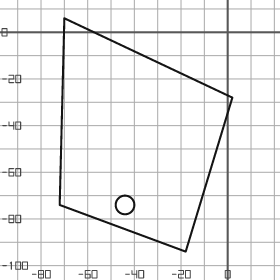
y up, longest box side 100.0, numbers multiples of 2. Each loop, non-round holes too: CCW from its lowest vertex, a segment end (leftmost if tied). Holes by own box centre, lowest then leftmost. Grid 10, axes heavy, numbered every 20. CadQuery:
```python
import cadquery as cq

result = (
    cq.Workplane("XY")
    .moveTo(-18.0, -94.0)
    .lineTo(2.0, -28.0)
    .lineTo(-70.0, 6.0)
    .lineTo(-72.0, -74.0)
    .close()
    .moveTo(-44.0, -74.0)
    .circle(4.0)
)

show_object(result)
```